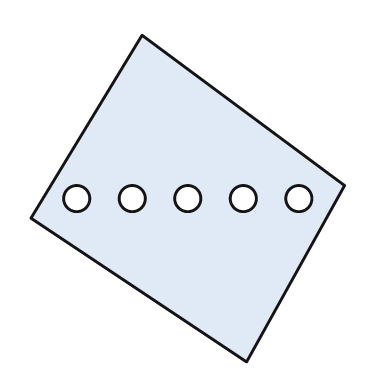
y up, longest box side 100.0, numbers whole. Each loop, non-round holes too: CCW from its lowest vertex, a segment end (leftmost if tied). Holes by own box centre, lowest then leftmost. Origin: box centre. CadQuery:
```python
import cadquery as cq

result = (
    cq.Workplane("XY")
    .moveTo(18.0, -50.0)
    .lineTo(48.0, 4.0)
    .lineTo(-14.0, 50.0)
    .lineTo(-48.0, -6.0)
    .close()
    .moveTo(-34.0, 0.0)
    .circle(4.0)
    .moveTo(-17.0, 0.0)
    .circle(4.0)
    .moveTo(0.0, 0.0)
    .circle(4.0)
    .moveTo(17.0, 0.0)
    .circle(4.0)
    .moveTo(34.0, 0.0)
    .circle(4.0)
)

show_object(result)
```